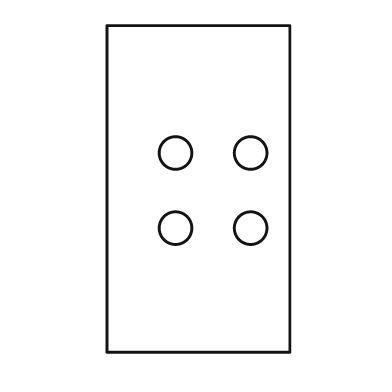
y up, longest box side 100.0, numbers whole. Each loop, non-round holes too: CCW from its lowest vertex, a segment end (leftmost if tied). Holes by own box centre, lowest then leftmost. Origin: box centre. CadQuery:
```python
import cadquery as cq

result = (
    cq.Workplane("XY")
    .moveTo(-28.0, -50.0)
    .lineTo(28.0, -50.0)
    .lineTo(28.0, 50.0)
    .lineTo(-28.0, 50.0)
    .close()
    .moveTo(-7.0, -12.0)
    .circle(5.0)
    .moveTo(16.0, -12.0)
    .circle(5.0)
    .moveTo(-7.0, 11.0)
    .circle(5.0)
    .moveTo(16.0, 11.0)
    .circle(5.0)
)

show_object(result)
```